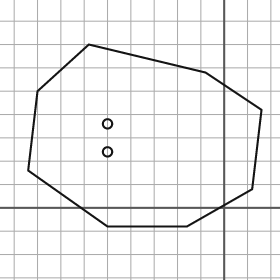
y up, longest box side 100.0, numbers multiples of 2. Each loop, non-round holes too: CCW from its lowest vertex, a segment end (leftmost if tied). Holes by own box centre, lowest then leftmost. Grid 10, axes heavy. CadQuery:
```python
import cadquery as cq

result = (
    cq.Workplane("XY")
    .moveTo(-50.0, -8.0)
    .lineTo(-16.0, -8.0)
    .lineTo(12.0, 8.0)
    .lineTo(16.0, 42.0)
    .lineTo(-8.0, 58.0)
    .lineTo(-58.0, 70.0)
    .lineTo(-80.0, 50.0)
    .lineTo(-84.0, 16.0)
    .close()
    .moveTo(-50.0, 24.0)
    .circle(2.0)
    .moveTo(-50.0, 36.0)
    .circle(2.0)
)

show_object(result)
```